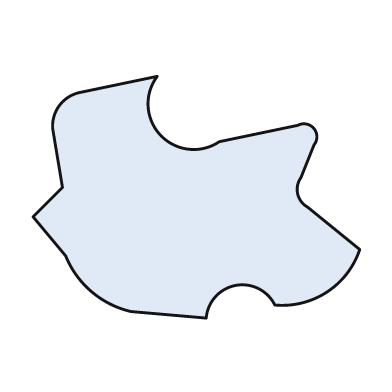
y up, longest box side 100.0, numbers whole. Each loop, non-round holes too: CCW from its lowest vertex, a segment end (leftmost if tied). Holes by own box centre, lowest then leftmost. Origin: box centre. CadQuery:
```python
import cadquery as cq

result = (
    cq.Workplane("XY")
    .moveTo(3.0, -37.0)
    .threePointArc((12.0, -27.0), (24.0, -33.0))
    .threePointArc((40.0, -29.0), (50.0, -16.0))
    .lineTo(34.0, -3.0)
    .threePointArc((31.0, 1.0), (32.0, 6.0))
    .lineTo(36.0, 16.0)
    .threePointArc((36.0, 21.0), (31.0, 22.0))
    .lineTo(7.0, 17.0)
    .threePointArc((-11.0, 19.0), (-12.0, 37.0))
    .lineTo(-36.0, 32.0)
    .threePointArc((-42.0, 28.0), (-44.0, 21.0))
    .lineTo(-41.0, 3.0)
    .lineTo(-50.0, -6.0)
    .lineTo(-40.0, -18.0)
    .threePointArc((-32.0, -29.0), (-20.0, -35.0))
    .close()
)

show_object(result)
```